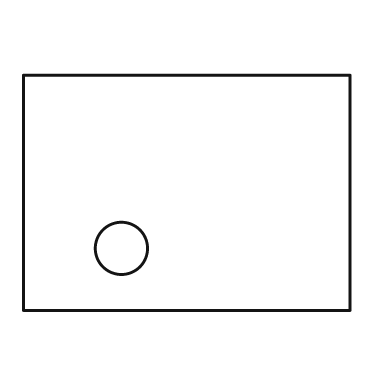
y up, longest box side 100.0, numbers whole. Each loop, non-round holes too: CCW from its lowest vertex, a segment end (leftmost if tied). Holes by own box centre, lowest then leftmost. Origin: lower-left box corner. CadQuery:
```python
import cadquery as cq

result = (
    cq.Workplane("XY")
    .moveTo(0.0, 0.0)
    .lineTo(100.0, 0.0)
    .lineTo(100.0, 72.0)
    .lineTo(0.0, 72.0)
    .close()
    .moveTo(30.0, 19.0)
    .circle(8.0)
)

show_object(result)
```